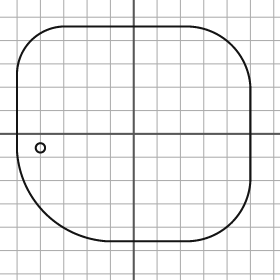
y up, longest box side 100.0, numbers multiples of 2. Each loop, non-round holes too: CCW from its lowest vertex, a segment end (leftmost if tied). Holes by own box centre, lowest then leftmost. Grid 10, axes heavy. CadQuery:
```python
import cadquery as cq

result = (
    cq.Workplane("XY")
    .moveTo(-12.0, -46.0)
    .lineTo(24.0, -46.0)
    .threePointArc((42.0, -38.0), (50.0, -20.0))
    .lineTo(50.0, 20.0)
    .threePointArc((42.0, 38.0), (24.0, 46.0))
    .lineTo(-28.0, 46.0)
    .threePointArc((-44.0, 40.0), (-50.0, 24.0))
    .lineTo(-50.0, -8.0)
    .threePointArc((-38.0, -34.0), (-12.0, -46.0))
    .close()
    .moveTo(-40.0, -6.0)
    .circle(2.0)
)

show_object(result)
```